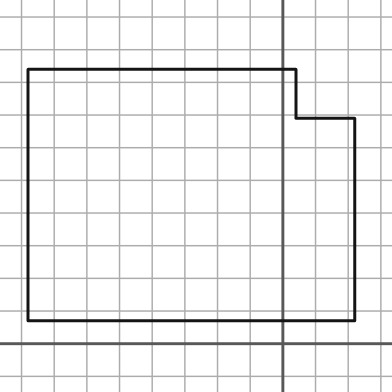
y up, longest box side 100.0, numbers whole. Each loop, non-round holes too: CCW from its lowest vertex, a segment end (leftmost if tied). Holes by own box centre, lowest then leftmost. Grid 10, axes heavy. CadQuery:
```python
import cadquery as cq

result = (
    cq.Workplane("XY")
    .moveTo(-78.0, 7.0)
    .lineTo(22.0, 7.0)
    .lineTo(22.0, 69.0)
    .lineTo(4.0, 69.0)
    .lineTo(4.0, 84.0)
    .lineTo(-78.0, 84.0)
    .close()
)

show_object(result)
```